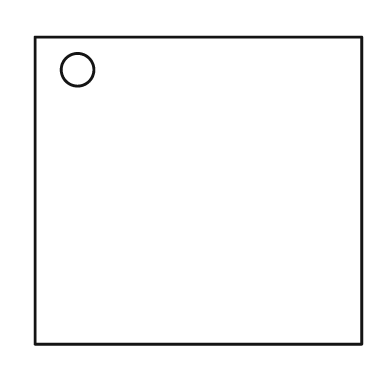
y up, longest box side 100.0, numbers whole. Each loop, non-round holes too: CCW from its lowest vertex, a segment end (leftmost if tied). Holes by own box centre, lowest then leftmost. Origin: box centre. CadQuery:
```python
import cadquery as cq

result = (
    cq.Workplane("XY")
    .moveTo(-50.0, -47.0)
    .lineTo(50.0, -47.0)
    .lineTo(50.0, 47.0)
    .lineTo(-50.0, 47.0)
    .close()
    .moveTo(-37.0, 37.0)
    .circle(5.0)
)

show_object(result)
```